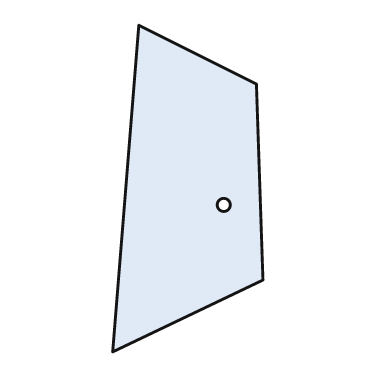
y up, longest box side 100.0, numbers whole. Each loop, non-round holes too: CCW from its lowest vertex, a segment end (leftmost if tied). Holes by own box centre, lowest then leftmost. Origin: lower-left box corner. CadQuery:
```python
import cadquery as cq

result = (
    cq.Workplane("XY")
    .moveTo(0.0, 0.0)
    .lineTo(46.0, 22.0)
    .lineTo(44.0, 82.0)
    .lineTo(8.0, 100.0)
    .close()
    .moveTo(34.0, 45.0)
    .circle(2.0)
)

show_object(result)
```